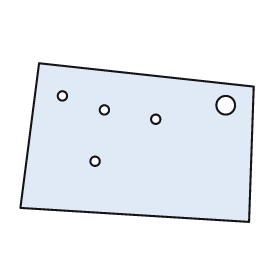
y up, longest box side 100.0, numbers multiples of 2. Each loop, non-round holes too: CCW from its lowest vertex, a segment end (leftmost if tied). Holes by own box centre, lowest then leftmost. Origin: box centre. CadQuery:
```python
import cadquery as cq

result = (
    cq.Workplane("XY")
    .moveTo(48.0, -34.0)
    .lineTo(50.0, 24.0)
    .lineTo(-42.0, 34.0)
    .lineTo(-50.0, -28.0)
    .close()
    .moveTo(-18.0, -8.0)
    .circle(2.0)
    .moveTo(8.0, 10.0)
    .circle(2.0)
    .moveTo(-14.0, 14.0)
    .circle(2.0)
    .moveTo(38.0, 16.0)
    .circle(4.0)
    .moveTo(-32.0, 20.0)
    .circle(2.0)
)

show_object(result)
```